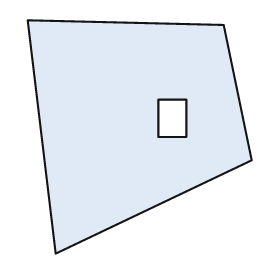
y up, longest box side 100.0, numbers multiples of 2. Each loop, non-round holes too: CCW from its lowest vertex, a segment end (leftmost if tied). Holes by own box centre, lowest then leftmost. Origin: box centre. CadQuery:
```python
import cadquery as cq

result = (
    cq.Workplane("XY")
    .moveTo(-36.0, -50.0)
    .lineTo(48.0, -10.0)
    .lineTo(36.0, 48.0)
    .lineTo(-48.0, 50.0)
    .close()
    .moveTo(8.0, 0.0)
    .lineTo(20.0, 0.0)
    .lineTo(20.0, 16.0)
    .lineTo(8.0, 16.0)
    .close()
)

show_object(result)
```